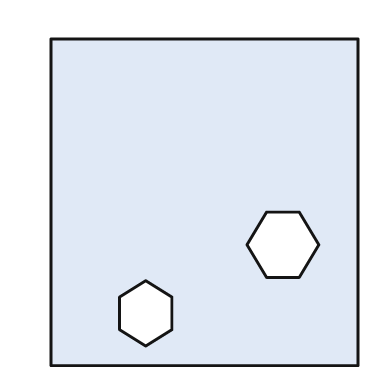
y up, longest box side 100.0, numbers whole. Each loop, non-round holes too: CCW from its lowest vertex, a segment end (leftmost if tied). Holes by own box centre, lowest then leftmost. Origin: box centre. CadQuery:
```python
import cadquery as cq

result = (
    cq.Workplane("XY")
    .moveTo(-47.0, -50.0)
    .lineTo(47.0, -50.0)
    .lineTo(47.0, 50.0)
    .lineTo(-47.0, 50.0)
    .close()
    .moveTo(-18.0, -44.0)
    .lineTo(-10.0, -39.0)
    .lineTo(-10.0, -29.0)
    .lineTo(-18.0, -24.0)
    .lineTo(-26.0, -29.0)
    .lineTo(-26.0, -39.0)
    .close()
    .moveTo(19.0, -23.0)
    .lineTo(29.0, -23.0)
    .lineTo(35.0, -13.0)
    .lineTo(29.0, -3.0)
    .lineTo(19.0, -3.0)
    .lineTo(13.0, -13.0)
    .close()
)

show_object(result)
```